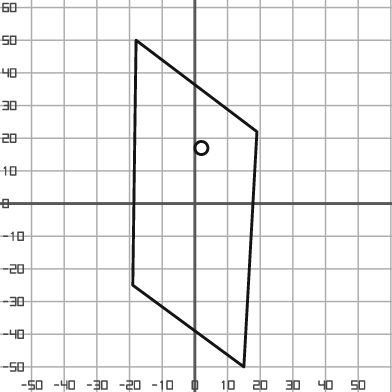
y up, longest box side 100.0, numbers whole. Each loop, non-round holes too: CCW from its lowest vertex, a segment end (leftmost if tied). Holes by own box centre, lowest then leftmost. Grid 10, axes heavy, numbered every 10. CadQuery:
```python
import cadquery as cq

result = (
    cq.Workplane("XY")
    .moveTo(15.0, -50.0)
    .lineTo(19.0, 22.0)
    .lineTo(-18.0, 50.0)
    .lineTo(-19.0, -25.0)
    .close()
    .moveTo(2.0, 17.0)
    .circle(2.0)
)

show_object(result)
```